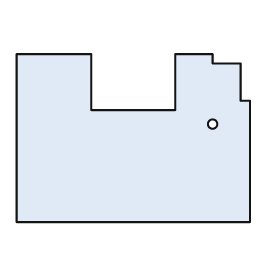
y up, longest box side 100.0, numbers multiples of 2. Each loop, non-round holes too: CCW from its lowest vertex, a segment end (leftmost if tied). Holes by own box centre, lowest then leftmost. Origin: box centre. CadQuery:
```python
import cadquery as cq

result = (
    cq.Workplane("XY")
    .moveTo(-50.0, -36.0)
    .lineTo(50.0, -36.0)
    .lineTo(50.0, 16.0)
    .lineTo(46.0, 16.0)
    .lineTo(46.0, 32.0)
    .lineTo(34.0, 32.0)
    .lineTo(34.0, 36.0)
    .lineTo(18.0, 36.0)
    .lineTo(18.0, 12.0)
    .lineTo(-18.0, 12.0)
    .lineTo(-18.0, 36.0)
    .lineTo(-50.0, 36.0)
    .close()
    .moveTo(34.0, 6.0)
    .circle(2.0)
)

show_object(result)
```